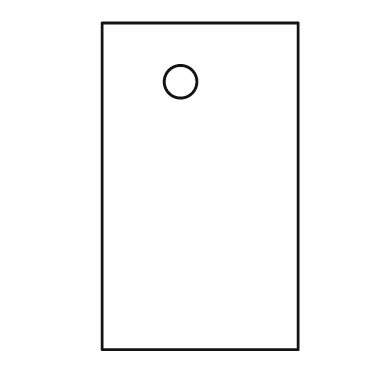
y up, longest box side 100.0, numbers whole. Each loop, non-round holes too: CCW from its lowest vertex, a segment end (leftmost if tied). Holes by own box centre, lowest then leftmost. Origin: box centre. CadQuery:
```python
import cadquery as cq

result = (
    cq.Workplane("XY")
    .moveTo(-30.0, -50.0)
    .lineTo(30.0, -50.0)
    .lineTo(30.0, 50.0)
    .lineTo(-30.0, 50.0)
    .close()
    .moveTo(-6.0, 32.0)
    .circle(5.0)
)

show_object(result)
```